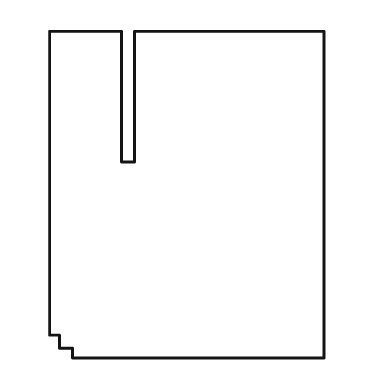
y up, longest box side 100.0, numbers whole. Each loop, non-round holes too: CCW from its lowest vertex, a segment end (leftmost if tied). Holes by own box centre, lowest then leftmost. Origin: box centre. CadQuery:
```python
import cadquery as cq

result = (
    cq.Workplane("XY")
    .moveTo(-35.0, -50.0)
    .lineTo(42.0, -50.0)
    .lineTo(42.0, 50.0)
    .lineTo(-16.0, 50.0)
    .lineTo(-16.0, 10.0)
    .lineTo(-20.0, 10.0)
    .lineTo(-20.0, 50.0)
    .lineTo(-42.0, 50.0)
    .lineTo(-42.0, -43.0)
    .lineTo(-39.0, -43.0)
    .lineTo(-39.0, -47.0)
    .lineTo(-35.0, -47.0)
    .close()
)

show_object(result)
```